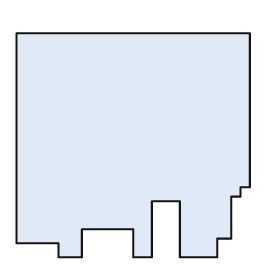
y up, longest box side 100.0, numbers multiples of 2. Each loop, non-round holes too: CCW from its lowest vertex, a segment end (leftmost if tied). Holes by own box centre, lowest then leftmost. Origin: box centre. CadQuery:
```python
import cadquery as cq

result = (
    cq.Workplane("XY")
    .moveTo(-32.0, -48.0)
    .lineTo(-22.0, -48.0)
    .lineTo(-22.0, -36.0)
    .lineTo(0.0, -36.0)
    .lineTo(0.0, -48.0)
    .lineTo(8.0, -48.0)
    .lineTo(8.0, -24.0)
    .lineTo(20.0, -24.0)
    .lineTo(20.0, -48.0)
    .lineTo(36.0, -48.0)
    .lineTo(36.0, -40.0)
    .lineTo(42.0, -40.0)
    .lineTo(42.0, -22.0)
    .lineTo(46.0, -22.0)
    .lineTo(46.0, -18.0)
    .lineTo(50.0, -18.0)
    .lineTo(50.0, 48.0)
    .lineTo(-50.0, 48.0)
    .lineTo(-50.0, -42.0)
    .lineTo(-32.0, -42.0)
    .close()
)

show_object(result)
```